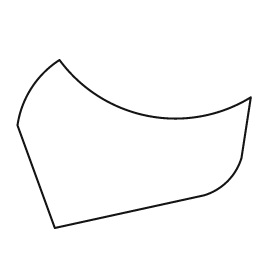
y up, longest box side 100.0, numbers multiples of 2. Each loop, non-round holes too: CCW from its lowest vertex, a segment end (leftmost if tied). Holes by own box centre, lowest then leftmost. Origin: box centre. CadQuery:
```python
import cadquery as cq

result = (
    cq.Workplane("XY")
    .moveTo(-34.0, -36.0)
    .lineTo(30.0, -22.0)
    .threePointArc((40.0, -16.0), (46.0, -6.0))
    .lineTo(50.0, 20.0)
    .threePointArc((6.0, 12.0), (-32.0, 36.0))
    .threePointArc((-44.0, 24.0), (-50.0, 8.0))
    .close()
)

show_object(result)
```